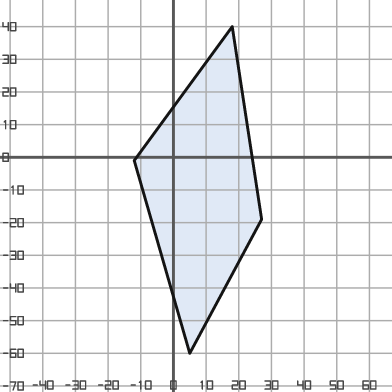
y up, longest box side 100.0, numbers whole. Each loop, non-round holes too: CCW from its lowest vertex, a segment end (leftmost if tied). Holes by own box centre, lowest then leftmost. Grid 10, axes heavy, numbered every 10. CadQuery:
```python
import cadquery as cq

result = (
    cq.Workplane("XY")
    .moveTo(5.0, -60.0)
    .lineTo(27.0, -19.0)
    .lineTo(18.0, 40.0)
    .lineTo(-12.0, -1.0)
    .close()
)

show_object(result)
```